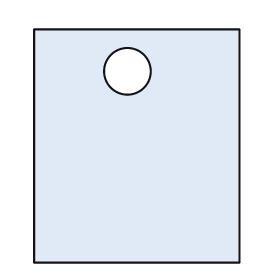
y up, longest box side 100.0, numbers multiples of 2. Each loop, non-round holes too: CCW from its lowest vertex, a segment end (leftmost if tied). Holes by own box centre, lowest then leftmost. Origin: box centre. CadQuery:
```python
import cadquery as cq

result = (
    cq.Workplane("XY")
    .moveTo(-44.0, -50.0)
    .lineTo(44.0, -50.0)
    .lineTo(44.0, 50.0)
    .lineTo(-44.0, 50.0)
    .close()
    .moveTo(-4.0, 32.0)
    .circle(10.0)
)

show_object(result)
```